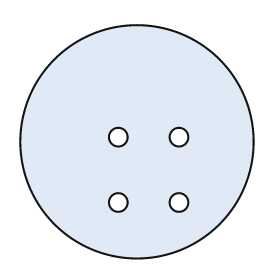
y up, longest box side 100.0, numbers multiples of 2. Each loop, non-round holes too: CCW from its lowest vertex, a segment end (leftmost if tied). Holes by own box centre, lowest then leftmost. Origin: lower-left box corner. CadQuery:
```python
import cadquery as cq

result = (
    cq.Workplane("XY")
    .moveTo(50.0, 50.0)
    .circle(50.0)
    .moveTo(42.0, 24.0)
    .circle(4.0)
    .moveTo(68.0, 24.0)
    .circle(4.0)
    .moveTo(42.0, 52.0)
    .circle(4.0)
    .moveTo(68.0, 52.0)
    .circle(4.0)
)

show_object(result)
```